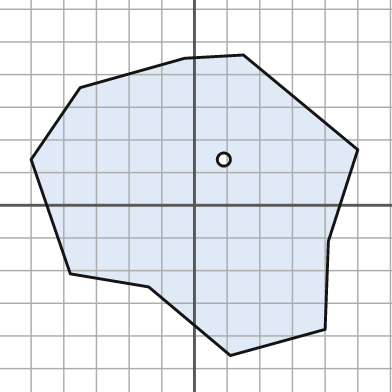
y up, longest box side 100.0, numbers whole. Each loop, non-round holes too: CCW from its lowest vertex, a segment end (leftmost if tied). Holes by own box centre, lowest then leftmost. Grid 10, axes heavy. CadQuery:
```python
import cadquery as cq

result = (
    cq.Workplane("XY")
    .moveTo(11.0, -46.0)
    .lineTo(40.0, -38.0)
    .lineTo(41.0, -11.0)
    .lineTo(50.0, 17.0)
    .lineTo(15.0, 46.0)
    .lineTo(-3.0, 45.0)
    .lineTo(-35.0, 36.0)
    .lineTo(-50.0, 14.0)
    .lineTo(-38.0, -21.0)
    .lineTo(-14.0, -25.0)
    .close()
    .moveTo(9.0, 14.0)
    .circle(2.0)
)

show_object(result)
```